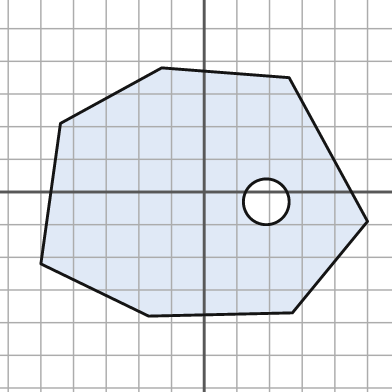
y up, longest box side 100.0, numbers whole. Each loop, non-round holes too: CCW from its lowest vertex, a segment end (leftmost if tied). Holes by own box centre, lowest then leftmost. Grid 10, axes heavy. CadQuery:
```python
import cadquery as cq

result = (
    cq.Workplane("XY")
    .moveTo(-17.0, -38.0)
    .lineTo(27.0, -37.0)
    .lineTo(50.0, -9.0)
    .lineTo(26.0, 35.0)
    .lineTo(-13.0, 38.0)
    .lineTo(-44.0, 21.0)
    .lineTo(-50.0, -22.0)
    .close()
    .moveTo(19.0, -3.0)
    .circle(7.0)
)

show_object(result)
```